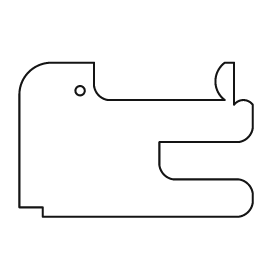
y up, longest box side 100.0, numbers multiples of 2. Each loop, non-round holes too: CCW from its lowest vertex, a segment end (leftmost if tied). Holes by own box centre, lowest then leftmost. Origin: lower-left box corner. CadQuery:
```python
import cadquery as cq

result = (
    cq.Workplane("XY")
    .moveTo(10.0, 0.0)
    .lineTo(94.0, 0.0)
    .threePointArc((98.0, 2.0), (100.0, 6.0))
    .lineTo(100.0, 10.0)
    .threePointArc((98.0, 14.0), (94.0, 16.0))
    .lineTo(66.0, 16.0)
    .threePointArc((62.0, 18.0), (60.0, 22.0))
    .lineTo(60.0, 32.0)
    .lineTo(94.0, 32.0)
    .threePointArc((98.0, 34.0), (100.0, 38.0))
    .lineTo(100.0, 48.0)
    .threePointArc((96.0, 50.0), (92.0, 48.0))
    .lineTo(92.0, 66.0)
    .lineTo(88.0, 66.0)
    .threePointArc((84.0, 58.0), (88.0, 50.0))
    .lineTo(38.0, 50.0)
    .threePointArc((34.0, 52.0), (32.0, 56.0))
    .lineTo(32.0, 66.0)
    .lineTo(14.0, 66.0)
    .threePointArc((4.0, 62.0), (0.0, 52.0))
    .lineTo(0.0, 4.0)
    .lineTo(10.0, 4.0)
    .close()
    .moveTo(26.0, 54.0)
    .circle(2.0)
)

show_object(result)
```